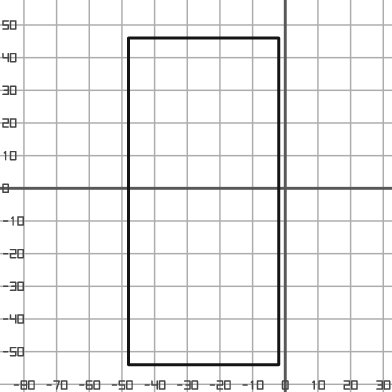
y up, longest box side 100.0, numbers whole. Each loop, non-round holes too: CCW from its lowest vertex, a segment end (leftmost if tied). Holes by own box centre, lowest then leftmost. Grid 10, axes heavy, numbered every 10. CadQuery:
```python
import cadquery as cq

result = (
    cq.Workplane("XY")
    .moveTo(-48.0, -54.0)
    .lineTo(-2.0, -54.0)
    .lineTo(-2.0, 46.0)
    .lineTo(-48.0, 46.0)
    .close()
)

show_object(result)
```